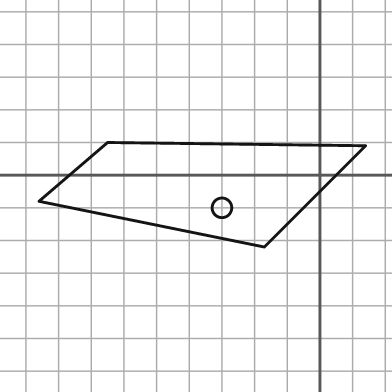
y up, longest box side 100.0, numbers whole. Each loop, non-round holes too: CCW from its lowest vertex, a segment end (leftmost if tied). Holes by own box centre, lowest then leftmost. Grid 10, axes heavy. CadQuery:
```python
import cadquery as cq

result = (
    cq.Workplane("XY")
    .moveTo(-17.0, -22.0)
    .lineTo(14.0, 9.0)
    .lineTo(-65.0, 10.0)
    .lineTo(-86.0, -8.0)
    .close()
    .moveTo(-30.0, -10.0)
    .circle(3.0)
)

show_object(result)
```